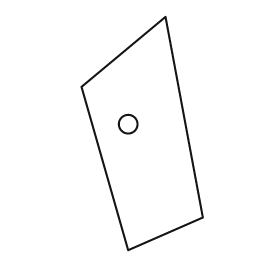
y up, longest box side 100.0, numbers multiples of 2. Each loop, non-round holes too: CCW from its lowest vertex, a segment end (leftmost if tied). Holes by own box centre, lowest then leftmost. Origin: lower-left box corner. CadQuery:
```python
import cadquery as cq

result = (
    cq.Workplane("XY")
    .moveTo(20.0, 0.0)
    .lineTo(52.0, 14.0)
    .lineTo(36.0, 100.0)
    .lineTo(0.0, 70.0)
    .close()
    .moveTo(20.0, 54.0)
    .circle(4.0)
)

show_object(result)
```